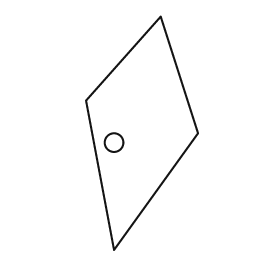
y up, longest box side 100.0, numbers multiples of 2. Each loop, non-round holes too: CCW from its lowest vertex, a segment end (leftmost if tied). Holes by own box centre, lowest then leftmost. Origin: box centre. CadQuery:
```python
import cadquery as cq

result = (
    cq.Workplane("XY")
    .moveTo(-12.0, -50.0)
    .lineTo(24.0, 0.0)
    .lineTo(8.0, 50.0)
    .lineTo(-24.0, 14.0)
    .close()
    .moveTo(-12.0, -4.0)
    .circle(4.0)
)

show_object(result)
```